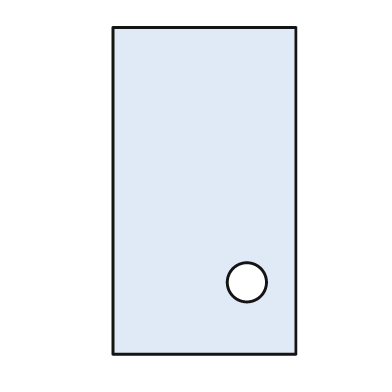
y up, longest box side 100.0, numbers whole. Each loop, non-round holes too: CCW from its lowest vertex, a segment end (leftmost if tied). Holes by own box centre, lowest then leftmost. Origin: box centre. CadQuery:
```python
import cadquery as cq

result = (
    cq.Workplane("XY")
    .moveTo(-28.0, -50.0)
    .lineTo(28.0, -50.0)
    .lineTo(28.0, 50.0)
    .lineTo(-28.0, 50.0)
    .close()
    .moveTo(13.0, -28.0)
    .circle(6.0)
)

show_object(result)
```